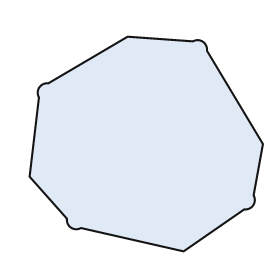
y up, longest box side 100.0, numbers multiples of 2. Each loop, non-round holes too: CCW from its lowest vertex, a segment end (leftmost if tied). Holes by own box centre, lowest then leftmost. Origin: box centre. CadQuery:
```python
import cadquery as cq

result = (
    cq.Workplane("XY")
    .moveTo(16.0, -46.0)
    .lineTo(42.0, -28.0)
    .threePointArc((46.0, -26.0), (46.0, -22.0))
    .lineTo(50.0, 0.0)
    .lineTo(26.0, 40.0)
    .threePointArc((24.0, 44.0), (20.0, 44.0))
    .lineTo(-8.0, 46.0)
    .lineTo(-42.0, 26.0)
    .threePointArc((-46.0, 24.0), (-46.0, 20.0))
    .lineTo(-50.0, -14.0)
    .lineTo(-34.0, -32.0)
    .threePointArc((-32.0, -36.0), (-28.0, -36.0))
    .close()
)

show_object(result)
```